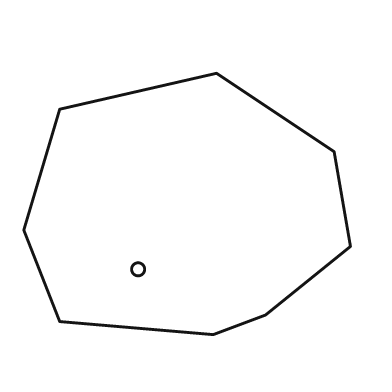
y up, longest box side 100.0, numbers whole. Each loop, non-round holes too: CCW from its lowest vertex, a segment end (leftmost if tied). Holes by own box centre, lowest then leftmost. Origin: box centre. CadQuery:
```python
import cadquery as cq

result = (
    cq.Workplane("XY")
    .moveTo(8.0, -40.0)
    .lineTo(24.0, -34.0)
    .lineTo(50.0, -13.0)
    .lineTo(45.0, 16.0)
    .lineTo(9.0, 40.0)
    .lineTo(-39.0, 29.0)
    .lineTo(-50.0, -8.0)
    .lineTo(-39.0, -36.0)
    .close()
    .moveTo(-15.0, -20.0)
    .circle(2.0)
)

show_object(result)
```